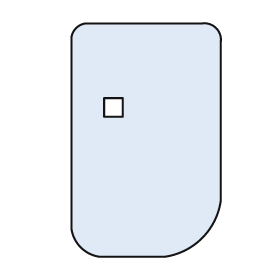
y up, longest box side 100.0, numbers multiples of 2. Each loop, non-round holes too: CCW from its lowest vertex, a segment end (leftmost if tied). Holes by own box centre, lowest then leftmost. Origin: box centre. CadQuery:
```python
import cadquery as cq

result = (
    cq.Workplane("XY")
    .moveTo(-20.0, -50.0)
    .lineTo(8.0, -50.0)
    .threePointArc((24.0, -42.0), (32.0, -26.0))
    .lineTo(32.0, 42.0)
    .threePointArc((30.0, 48.0), (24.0, 50.0))
    .lineTo(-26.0, 50.0)
    .threePointArc((-30.0, 48.0), (-32.0, 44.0))
    .lineTo(-32.0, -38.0)
    .threePointArc((-28.0, -46.0), (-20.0, -50.0))
    .close()
    .moveTo(-18.0, 10.0)
    .lineTo(-10.0, 10.0)
    .lineTo(-10.0, 18.0)
    .lineTo(-18.0, 18.0)
    .close()
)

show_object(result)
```